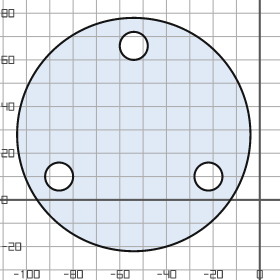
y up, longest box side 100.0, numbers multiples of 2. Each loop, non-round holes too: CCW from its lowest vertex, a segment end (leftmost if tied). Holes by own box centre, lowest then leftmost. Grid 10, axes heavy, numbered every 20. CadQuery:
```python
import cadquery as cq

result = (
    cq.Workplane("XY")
    .moveTo(-54.0, 28.0)
    .circle(50.0)
    .moveTo(-86.0, 10.0)
    .circle(6.0)
    .moveTo(-22.0, 10.0)
    .circle(6.0)
    .moveTo(-54.0, 66.0)
    .circle(6.0)
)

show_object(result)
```